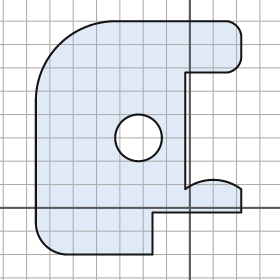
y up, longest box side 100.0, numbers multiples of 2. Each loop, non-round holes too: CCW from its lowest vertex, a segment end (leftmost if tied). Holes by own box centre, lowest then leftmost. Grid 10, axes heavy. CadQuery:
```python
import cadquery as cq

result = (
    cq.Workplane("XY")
    .moveTo(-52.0, -20.0)
    .lineTo(-16.0, -20.0)
    .lineTo(-16.0, -2.0)
    .lineTo(22.0, -2.0)
    .lineTo(22.0, 8.0)
    .threePointArc((10.0, 12.0), (-2.0, 8.0))
    .lineTo(-2.0, 58.0)
    .lineTo(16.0, 58.0)
    .threePointArc((20.0, 60.0), (22.0, 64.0))
    .lineTo(22.0, 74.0)
    .threePointArc((20.0, 78.0), (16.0, 80.0))
    .lineTo(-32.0, 80.0)
    .threePointArc((-56.0, 70.0), (-66.0, 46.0))
    .lineTo(-66.0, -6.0)
    .threePointArc((-62.0, -16.0), (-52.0, -20.0))
    .close()
    .moveTo(-22.0, 30.0)
    .circle(10.0)
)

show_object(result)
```